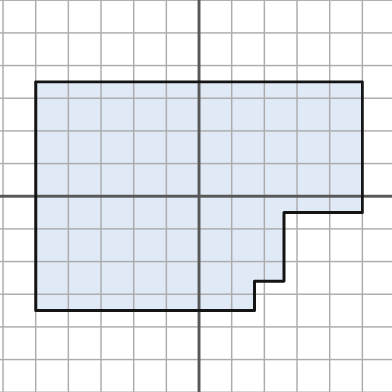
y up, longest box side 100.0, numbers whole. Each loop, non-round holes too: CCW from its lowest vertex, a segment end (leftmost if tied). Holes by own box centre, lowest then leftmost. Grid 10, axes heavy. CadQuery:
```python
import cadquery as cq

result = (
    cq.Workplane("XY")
    .moveTo(-50.0, -35.0)
    .lineTo(17.0, -35.0)
    .lineTo(17.0, -26.0)
    .lineTo(26.0, -26.0)
    .lineTo(26.0, -5.0)
    .lineTo(50.0, -5.0)
    .lineTo(50.0, 35.0)
    .lineTo(-50.0, 35.0)
    .close()
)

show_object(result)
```